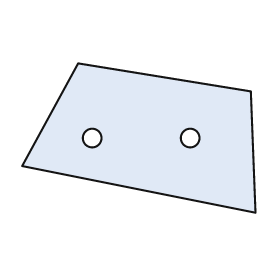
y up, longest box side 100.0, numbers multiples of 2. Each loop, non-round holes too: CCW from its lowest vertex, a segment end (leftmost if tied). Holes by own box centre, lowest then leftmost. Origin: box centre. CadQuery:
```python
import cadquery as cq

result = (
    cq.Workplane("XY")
    .moveTo(50.0, -32.0)
    .lineTo(48.0, 20.0)
    .lineTo(-26.0, 32.0)
    .lineTo(-50.0, -12.0)
    .close()
    .moveTo(-20.0, 0.0)
    .circle(4.0)
    .moveTo(22.0, 0.0)
    .circle(4.0)
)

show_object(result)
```